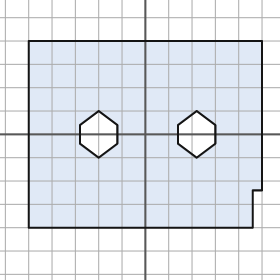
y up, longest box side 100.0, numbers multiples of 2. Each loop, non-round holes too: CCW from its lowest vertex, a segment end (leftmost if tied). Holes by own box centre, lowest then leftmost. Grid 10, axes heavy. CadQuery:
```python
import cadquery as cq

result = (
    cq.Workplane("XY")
    .moveTo(-50.0, -40.0)
    .lineTo(46.0, -40.0)
    .lineTo(46.0, -24.0)
    .lineTo(50.0, -24.0)
    .lineTo(50.0, 40.0)
    .lineTo(-50.0, 40.0)
    .close()
    .moveTo(-20.0, -10.0)
    .lineTo(-12.0, -4.0)
    .lineTo(-12.0, 4.0)
    .lineTo(-20.0, 10.0)
    .lineTo(-28.0, 4.0)
    .lineTo(-28.0, -4.0)
    .close()
    .moveTo(22.0, -10.0)
    .lineTo(30.0, -4.0)
    .lineTo(30.0, 4.0)
    .lineTo(22.0, 10.0)
    .lineTo(14.0, 4.0)
    .lineTo(14.0, -4.0)
    .close()
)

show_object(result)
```